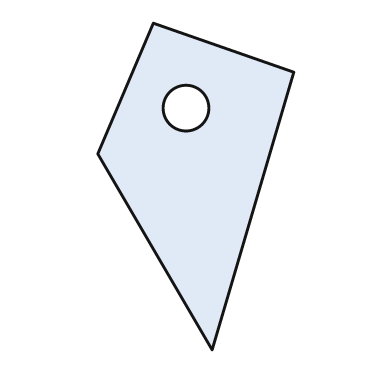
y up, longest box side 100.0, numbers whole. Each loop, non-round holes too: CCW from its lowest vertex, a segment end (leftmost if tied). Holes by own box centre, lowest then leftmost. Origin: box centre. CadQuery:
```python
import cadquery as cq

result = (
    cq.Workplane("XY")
    .moveTo(5.0, -50.0)
    .lineTo(30.0, 35.0)
    .lineTo(-13.0, 50.0)
    .lineTo(-30.0, 10.0)
    .close()
    .moveTo(-3.0, 24.0)
    .circle(7.0)
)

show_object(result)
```